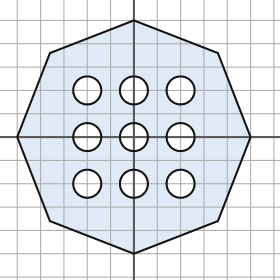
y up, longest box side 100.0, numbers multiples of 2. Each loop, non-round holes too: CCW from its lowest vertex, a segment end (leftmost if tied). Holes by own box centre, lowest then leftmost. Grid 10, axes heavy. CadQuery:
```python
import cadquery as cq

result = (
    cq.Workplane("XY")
    .moveTo(0.0, -50.0)
    .lineTo(36.0, -36.0)
    .lineTo(50.0, 0.0)
    .lineTo(36.0, 36.0)
    .lineTo(0.0, 50.0)
    .lineTo(-36.0, 36.0)
    .lineTo(-50.0, 0.0)
    .lineTo(-36.0, -36.0)
    .close()
    .moveTo(-20.0, -20.0)
    .circle(6.0)
    .moveTo(0.0, -20.0)
    .circle(6.0)
    .moveTo(20.0, -20.0)
    .circle(6.0)
    .moveTo(-20.0, 0.0)
    .circle(6.0)
    .moveTo(0.0, 0.0)
    .circle(6.0)
    .moveTo(20.0, 0.0)
    .circle(6.0)
    .moveTo(-20.0, 20.0)
    .circle(6.0)
    .moveTo(0.0, 20.0)
    .circle(6.0)
    .moveTo(20.0, 20.0)
    .circle(6.0)
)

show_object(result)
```